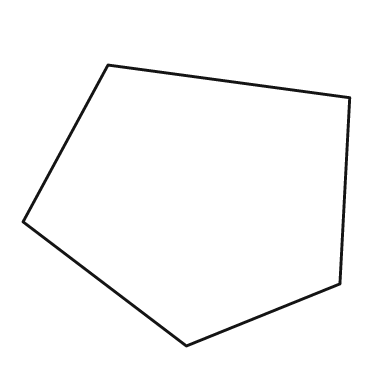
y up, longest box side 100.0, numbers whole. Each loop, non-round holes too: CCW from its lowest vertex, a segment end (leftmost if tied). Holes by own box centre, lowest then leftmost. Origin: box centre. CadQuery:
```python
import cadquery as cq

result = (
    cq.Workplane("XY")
    .moveTo(0.0, -43.0)
    .lineTo(47.0, -24.0)
    .lineTo(50.0, 33.0)
    .lineTo(-24.0, 43.0)
    .lineTo(-50.0, -5.0)
    .close()
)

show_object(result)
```